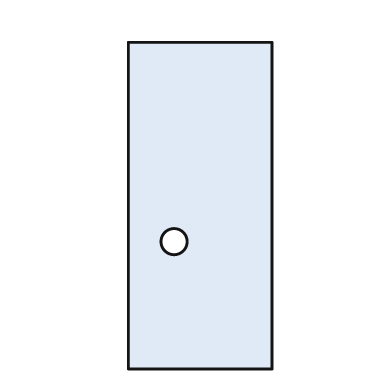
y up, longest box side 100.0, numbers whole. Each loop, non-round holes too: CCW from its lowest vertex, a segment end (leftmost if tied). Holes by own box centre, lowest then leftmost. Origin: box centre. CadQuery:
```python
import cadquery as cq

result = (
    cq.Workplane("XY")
    .moveTo(-22.0, -50.0)
    .lineTo(22.0, -50.0)
    .lineTo(22.0, 50.0)
    .lineTo(-22.0, 50.0)
    .close()
    .moveTo(-8.0, -11.0)
    .circle(4.0)
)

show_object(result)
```